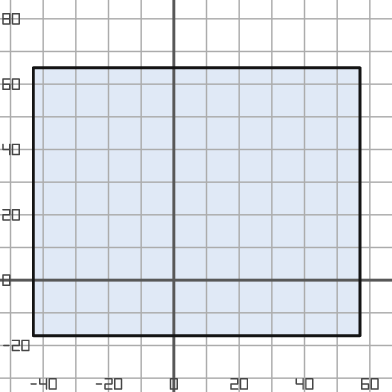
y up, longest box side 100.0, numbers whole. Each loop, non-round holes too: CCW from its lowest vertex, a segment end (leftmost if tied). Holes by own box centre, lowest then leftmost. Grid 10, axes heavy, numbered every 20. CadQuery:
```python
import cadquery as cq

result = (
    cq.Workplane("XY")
    .moveTo(-43.0, -17.0)
    .lineTo(57.0, -17.0)
    .lineTo(57.0, 65.0)
    .lineTo(-43.0, 65.0)
    .close()
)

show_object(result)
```